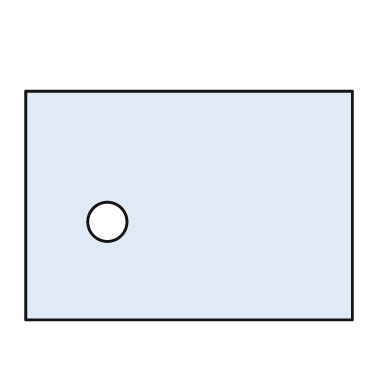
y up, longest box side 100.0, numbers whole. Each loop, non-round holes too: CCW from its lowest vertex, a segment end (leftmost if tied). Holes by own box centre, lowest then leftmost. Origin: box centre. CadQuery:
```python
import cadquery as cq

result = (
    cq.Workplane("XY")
    .moveTo(-50.0, -35.0)
    .lineTo(50.0, -35.0)
    .lineTo(50.0, 35.0)
    .lineTo(-50.0, 35.0)
    .close()
    .moveTo(-25.0, -5.0)
    .circle(6.0)
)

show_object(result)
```